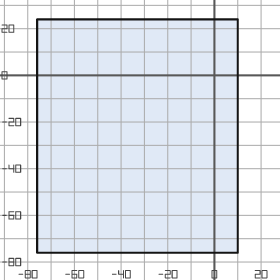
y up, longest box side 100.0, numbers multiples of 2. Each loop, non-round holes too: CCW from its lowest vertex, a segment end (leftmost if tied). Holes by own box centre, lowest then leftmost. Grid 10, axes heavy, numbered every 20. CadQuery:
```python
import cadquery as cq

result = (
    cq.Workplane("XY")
    .moveTo(-76.0, -76.0)
    .lineTo(10.0, -76.0)
    .lineTo(10.0, 24.0)
    .lineTo(-76.0, 24.0)
    .close()
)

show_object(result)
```